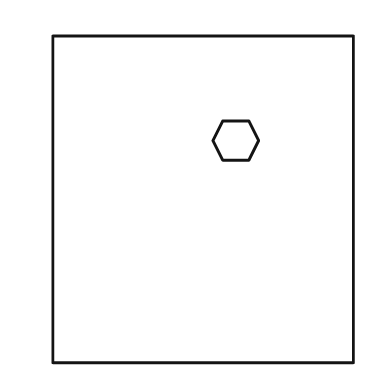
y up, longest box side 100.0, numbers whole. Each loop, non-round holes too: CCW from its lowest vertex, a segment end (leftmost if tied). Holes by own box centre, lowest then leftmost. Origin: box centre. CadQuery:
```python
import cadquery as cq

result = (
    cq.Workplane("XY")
    .moveTo(-46.0, -50.0)
    .lineTo(46.0, -50.0)
    .lineTo(46.0, 50.0)
    .lineTo(-46.0, 50.0)
    .close()
    .moveTo(6.0, 12.0)
    .lineTo(14.0, 12.0)
    .lineTo(17.0, 18.0)
    .lineTo(14.0, 24.0)
    .lineTo(6.0, 24.0)
    .lineTo(3.0, 18.0)
    .close()
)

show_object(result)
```